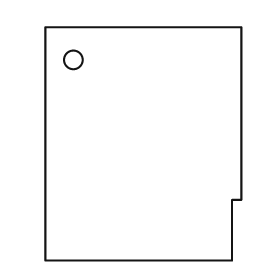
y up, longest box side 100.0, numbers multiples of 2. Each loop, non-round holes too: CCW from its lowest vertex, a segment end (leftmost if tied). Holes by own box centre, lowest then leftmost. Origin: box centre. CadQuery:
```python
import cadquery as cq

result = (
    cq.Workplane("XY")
    .moveTo(-42.0, -50.0)
    .lineTo(38.0, -50.0)
    .lineTo(38.0, -24.0)
    .lineTo(42.0, -24.0)
    .lineTo(42.0, 50.0)
    .lineTo(-42.0, 50.0)
    .close()
    .moveTo(-30.0, 36.0)
    .circle(4.0)
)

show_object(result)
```